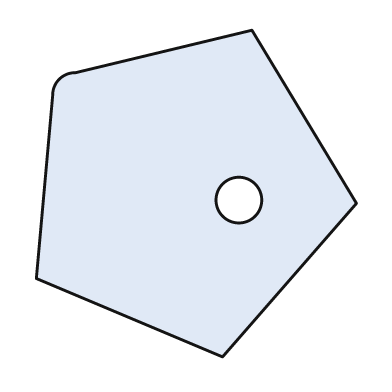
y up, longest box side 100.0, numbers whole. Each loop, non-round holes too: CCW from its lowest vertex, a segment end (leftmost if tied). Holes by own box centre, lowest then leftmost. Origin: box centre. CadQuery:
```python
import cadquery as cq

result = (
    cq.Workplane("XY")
    .moveTo(8.0, -50.0)
    .lineTo(49.0, -3.0)
    .lineTo(17.0, 50.0)
    .lineTo(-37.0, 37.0)
    .threePointArc((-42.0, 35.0), (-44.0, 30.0))
    .lineTo(-49.0, -26.0)
    .close()
    .moveTo(13.0, -2.0)
    .circle(7.0)
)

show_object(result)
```